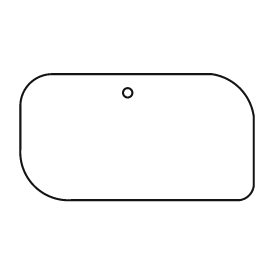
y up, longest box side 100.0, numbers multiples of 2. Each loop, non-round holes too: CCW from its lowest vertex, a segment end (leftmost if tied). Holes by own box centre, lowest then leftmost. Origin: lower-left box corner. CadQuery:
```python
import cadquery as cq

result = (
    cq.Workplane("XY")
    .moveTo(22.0, 0.0)
    .lineTo(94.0, 0.0)
    .threePointArc((98.0, 2.0), (100.0, 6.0))
    .lineTo(100.0, 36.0)
    .threePointArc((94.0, 48.0), (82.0, 54.0))
    .lineTo(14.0, 54.0)
    .threePointArc((4.0, 50.0), (0.0, 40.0))
    .lineTo(0.0, 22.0)
    .threePointArc((6.0, 6.0), (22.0, 0.0))
    .close()
    .moveTo(46.0, 46.0)
    .circle(2.0)
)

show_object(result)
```